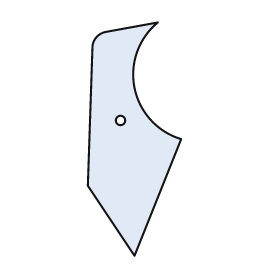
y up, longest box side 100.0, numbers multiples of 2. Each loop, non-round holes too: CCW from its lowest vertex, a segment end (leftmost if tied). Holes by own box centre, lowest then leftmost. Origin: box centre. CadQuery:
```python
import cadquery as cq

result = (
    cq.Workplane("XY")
    .moveTo(0.0, -50.0)
    .lineTo(20.0, 0.0)
    .threePointArc((0.0, 22.0), (10.0, 50.0))
    .lineTo(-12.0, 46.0)
    .threePointArc((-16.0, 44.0), (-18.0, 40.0))
    .lineTo(-20.0, -20.0)
    .close()
    .moveTo(-6.0, 8.0)
    .circle(2.0)
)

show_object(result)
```